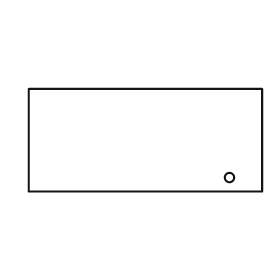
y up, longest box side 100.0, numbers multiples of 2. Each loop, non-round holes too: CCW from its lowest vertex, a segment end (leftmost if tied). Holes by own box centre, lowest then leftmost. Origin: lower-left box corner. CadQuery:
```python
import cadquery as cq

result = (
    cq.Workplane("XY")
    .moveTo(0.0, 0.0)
    .lineTo(100.0, 0.0)
    .lineTo(100.0, 44.0)
    .lineTo(0.0, 44.0)
    .close()
    .moveTo(86.0, 6.0)
    .circle(2.0)
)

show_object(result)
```